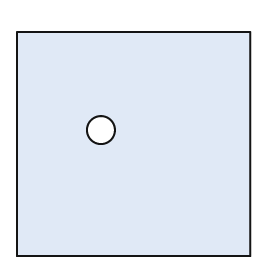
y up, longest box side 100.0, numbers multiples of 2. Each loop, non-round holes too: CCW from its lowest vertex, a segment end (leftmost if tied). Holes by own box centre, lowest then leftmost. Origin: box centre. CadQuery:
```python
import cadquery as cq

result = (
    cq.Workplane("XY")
    .moveTo(-50.0, -48.0)
    .lineTo(50.0, -48.0)
    .lineTo(50.0, 48.0)
    .lineTo(-50.0, 48.0)
    .close()
    .moveTo(-14.0, 6.0)
    .circle(6.0)
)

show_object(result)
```